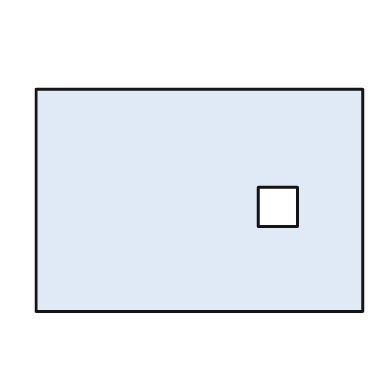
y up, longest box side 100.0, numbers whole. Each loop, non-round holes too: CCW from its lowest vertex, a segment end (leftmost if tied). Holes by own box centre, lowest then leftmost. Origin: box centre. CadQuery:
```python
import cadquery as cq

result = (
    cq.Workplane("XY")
    .moveTo(-50.0, -34.0)
    .lineTo(50.0, -34.0)
    .lineTo(50.0, 34.0)
    .lineTo(-50.0, 34.0)
    .close()
    .moveTo(18.0, -8.0)
    .lineTo(30.0, -8.0)
    .lineTo(30.0, 4.0)
    .lineTo(18.0, 4.0)
    .close()
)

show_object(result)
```